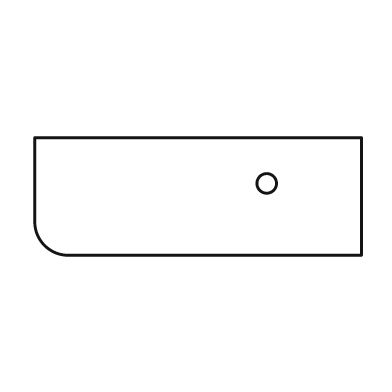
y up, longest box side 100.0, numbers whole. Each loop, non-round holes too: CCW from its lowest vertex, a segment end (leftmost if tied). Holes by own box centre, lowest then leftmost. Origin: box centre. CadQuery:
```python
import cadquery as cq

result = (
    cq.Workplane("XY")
    .moveTo(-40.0, -18.0)
    .lineTo(50.0, -18.0)
    .lineTo(50.0, 18.0)
    .lineTo(-50.0, 18.0)
    .lineTo(-50.0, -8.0)
    .threePointArc((-47.0, -15.0), (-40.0, -18.0))
    .close()
    .moveTo(21.0, 4.0)
    .circle(3.0)
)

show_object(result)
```